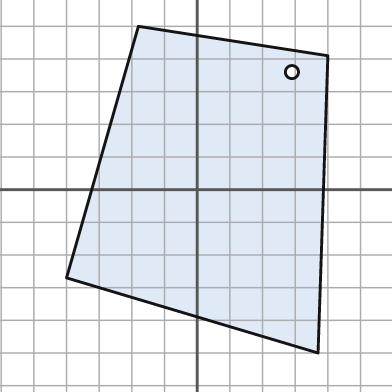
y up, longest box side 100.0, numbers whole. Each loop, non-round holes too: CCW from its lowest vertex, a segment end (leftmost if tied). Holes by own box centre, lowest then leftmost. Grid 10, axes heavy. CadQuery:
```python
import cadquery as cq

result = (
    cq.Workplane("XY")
    .moveTo(37.0, -50.0)
    .lineTo(40.0, 41.0)
    .lineTo(-18.0, 50.0)
    .lineTo(-40.0, -27.0)
    .close()
    .moveTo(29.0, 36.0)
    .circle(2.0)
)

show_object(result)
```